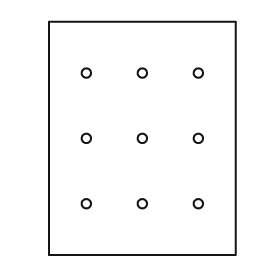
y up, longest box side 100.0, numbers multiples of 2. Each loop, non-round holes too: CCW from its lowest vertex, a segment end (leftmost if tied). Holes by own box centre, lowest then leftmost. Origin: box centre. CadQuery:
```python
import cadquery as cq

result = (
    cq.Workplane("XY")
    .moveTo(-40.0, -50.0)
    .lineTo(40.0, -50.0)
    .lineTo(40.0, 50.0)
    .lineTo(-40.0, 50.0)
    .close()
    .moveTo(-24.0, -28.0)
    .circle(2.0)
    .moveTo(0.0, -28.0)
    .circle(2.0)
    .moveTo(24.0, -28.0)
    .circle(2.0)
    .moveTo(-24.0, 0.0)
    .circle(2.0)
    .moveTo(0.0, 0.0)
    .circle(2.0)
    .moveTo(24.0, 0.0)
    .circle(2.0)
    .moveTo(-24.0, 28.0)
    .circle(2.0)
    .moveTo(0.0, 28.0)
    .circle(2.0)
    .moveTo(24.0, 28.0)
    .circle(2.0)
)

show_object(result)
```